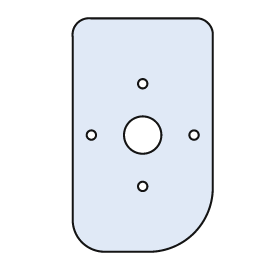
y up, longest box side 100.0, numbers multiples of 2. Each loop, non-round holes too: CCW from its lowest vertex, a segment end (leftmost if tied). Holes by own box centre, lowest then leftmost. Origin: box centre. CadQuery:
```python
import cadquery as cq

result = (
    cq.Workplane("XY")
    .moveTo(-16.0, -50.0)
    .lineTo(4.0, -50.0)
    .threePointArc((22.0, -42.0), (30.0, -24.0))
    .lineTo(30.0, 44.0)
    .threePointArc((28.0, 48.0), (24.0, 50.0))
    .lineTo(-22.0, 50.0)
    .threePointArc((-28.0, 48.0), (-30.0, 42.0))
    .lineTo(-30.0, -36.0)
    .threePointArc((-26.0, -46.0), (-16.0, -50.0))
    .close()
    .moveTo(0.0, -22.0)
    .circle(2.0)
    .moveTo(-22.0, 0.0)
    .circle(2.0)
    .moveTo(0.0, 0.0)
    .circle(8.0)
    .moveTo(22.0, 0.0)
    .circle(2.0)
    .moveTo(0.0, 22.0)
    .circle(2.0)
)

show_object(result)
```